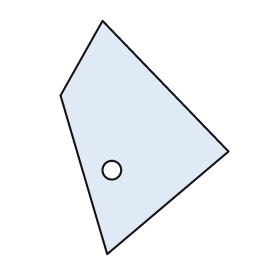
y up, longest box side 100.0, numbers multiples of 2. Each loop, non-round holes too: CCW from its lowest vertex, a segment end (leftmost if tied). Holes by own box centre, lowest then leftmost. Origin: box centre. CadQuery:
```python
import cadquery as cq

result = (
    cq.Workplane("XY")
    .moveTo(-16.0, -50.0)
    .lineTo(36.0, -6.0)
    .lineTo(-18.0, 50.0)
    .lineTo(-36.0, 18.0)
    .close()
    .moveTo(-14.0, -14.0)
    .circle(4.0)
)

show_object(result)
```